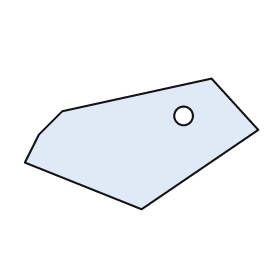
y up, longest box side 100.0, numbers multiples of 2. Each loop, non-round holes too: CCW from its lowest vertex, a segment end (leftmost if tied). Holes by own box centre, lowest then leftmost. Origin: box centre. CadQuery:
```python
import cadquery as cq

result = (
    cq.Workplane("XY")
    .moveTo(0.0, -28.0)
    .lineTo(50.0, 6.0)
    .lineTo(30.0, 28.0)
    .lineTo(-34.0, 14.0)
    .lineTo(-44.0, 4.0)
    .lineTo(-50.0, -8.0)
    .close()
    .moveTo(18.0, 12.0)
    .circle(4.0)
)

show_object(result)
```